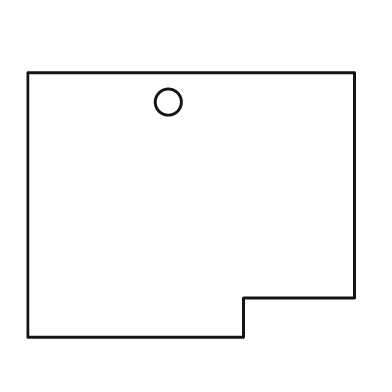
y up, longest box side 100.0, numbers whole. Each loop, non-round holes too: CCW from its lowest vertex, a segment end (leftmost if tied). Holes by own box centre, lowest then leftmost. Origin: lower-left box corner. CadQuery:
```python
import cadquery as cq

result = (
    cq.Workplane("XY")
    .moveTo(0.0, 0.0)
    .lineTo(66.0, 0.0)
    .lineTo(66.0, 12.0)
    .lineTo(100.0, 12.0)
    .lineTo(100.0, 81.0)
    .lineTo(0.0, 81.0)
    .close()
    .moveTo(43.0, 72.0)
    .circle(4.0)
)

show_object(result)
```